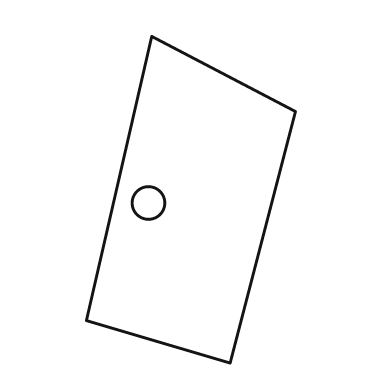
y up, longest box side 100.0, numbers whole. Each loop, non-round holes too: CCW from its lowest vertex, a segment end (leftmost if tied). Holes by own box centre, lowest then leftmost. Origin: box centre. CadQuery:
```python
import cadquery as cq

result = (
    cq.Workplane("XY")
    .moveTo(12.0, -50.0)
    .lineTo(32.0, 27.0)
    .lineTo(-12.0, 50.0)
    .lineTo(-32.0, -37.0)
    .close()
    .moveTo(-13.0, -1.0)
    .circle(5.0)
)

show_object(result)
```